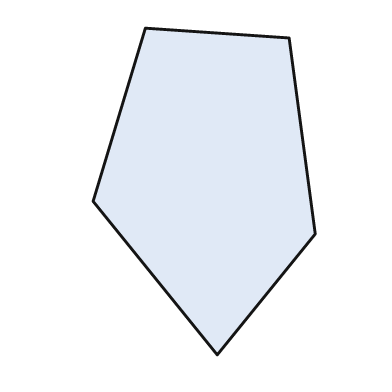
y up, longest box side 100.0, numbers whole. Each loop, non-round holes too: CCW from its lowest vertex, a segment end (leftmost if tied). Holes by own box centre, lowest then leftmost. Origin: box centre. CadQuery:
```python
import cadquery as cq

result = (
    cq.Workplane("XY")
    .moveTo(4.0, -50.0)
    .lineTo(34.0, -13.0)
    .lineTo(26.0, 47.0)
    .lineTo(-18.0, 50.0)
    .lineTo(-34.0, -3.0)
    .close()
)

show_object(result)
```